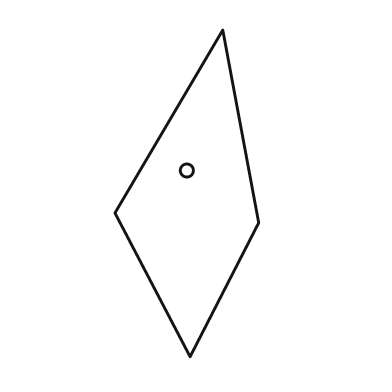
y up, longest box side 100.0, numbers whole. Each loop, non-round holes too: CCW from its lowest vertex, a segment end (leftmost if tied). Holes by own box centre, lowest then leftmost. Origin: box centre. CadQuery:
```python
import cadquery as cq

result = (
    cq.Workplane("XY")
    .moveTo(1.0, -50.0)
    .lineTo(22.0, -9.0)
    .lineTo(11.0, 50.0)
    .lineTo(-22.0, -6.0)
    .close()
    .moveTo(0.0, 7.0)
    .circle(2.0)
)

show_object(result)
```